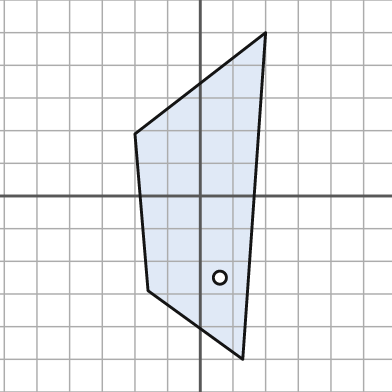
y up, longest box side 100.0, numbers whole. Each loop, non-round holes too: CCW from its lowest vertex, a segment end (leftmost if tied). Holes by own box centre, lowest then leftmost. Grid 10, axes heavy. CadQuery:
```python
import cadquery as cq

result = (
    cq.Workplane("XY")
    .moveTo(13.0, -50.0)
    .lineTo(20.0, 50.0)
    .lineTo(-20.0, 19.0)
    .lineTo(-16.0, -29.0)
    .close()
    .moveTo(6.0, -25.0)
    .circle(2.0)
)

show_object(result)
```